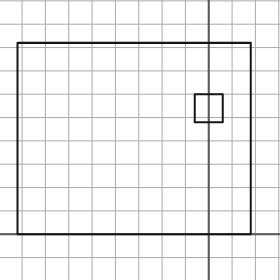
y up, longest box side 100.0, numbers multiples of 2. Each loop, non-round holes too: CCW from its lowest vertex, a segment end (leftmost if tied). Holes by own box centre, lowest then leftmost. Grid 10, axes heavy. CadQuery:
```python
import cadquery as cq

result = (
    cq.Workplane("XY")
    .moveTo(-82.0, 0.0)
    .lineTo(18.0, 0.0)
    .lineTo(18.0, 82.0)
    .lineTo(-82.0, 82.0)
    .close()
    .moveTo(-6.0, 48.0)
    .lineTo(6.0, 48.0)
    .lineTo(6.0, 60.0)
    .lineTo(-6.0, 60.0)
    .close()
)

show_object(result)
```